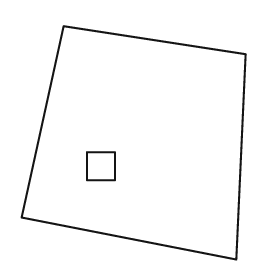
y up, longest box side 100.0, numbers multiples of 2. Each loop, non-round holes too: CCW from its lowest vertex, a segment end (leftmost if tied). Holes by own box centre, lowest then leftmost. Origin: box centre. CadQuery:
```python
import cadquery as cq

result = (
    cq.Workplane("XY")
    .moveTo(44.0, -50.0)
    .lineTo(48.0, 38.0)
    .lineTo(-30.0, 50.0)
    .lineTo(-48.0, -32.0)
    .close()
    .moveTo(-20.0, -16.0)
    .lineTo(-8.0, -16.0)
    .lineTo(-8.0, -4.0)
    .lineTo(-20.0, -4.0)
    .close()
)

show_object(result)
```